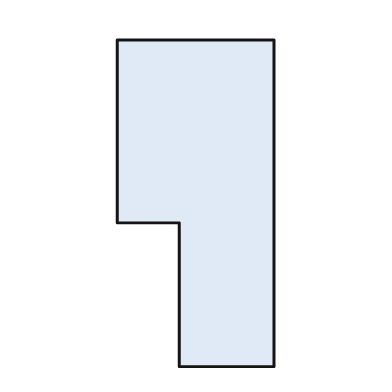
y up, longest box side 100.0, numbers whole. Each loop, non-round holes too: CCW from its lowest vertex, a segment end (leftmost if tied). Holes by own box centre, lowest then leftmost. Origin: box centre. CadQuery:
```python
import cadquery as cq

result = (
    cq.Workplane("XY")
    .moveTo(-5.0, -50.0)
    .lineTo(24.0, -50.0)
    .lineTo(24.0, 50.0)
    .lineTo(-24.0, 50.0)
    .lineTo(-24.0, -6.0)
    .lineTo(-5.0, -6.0)
    .close()
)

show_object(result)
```